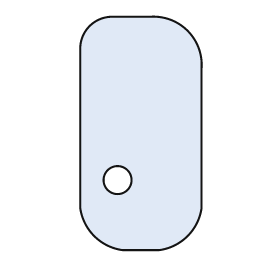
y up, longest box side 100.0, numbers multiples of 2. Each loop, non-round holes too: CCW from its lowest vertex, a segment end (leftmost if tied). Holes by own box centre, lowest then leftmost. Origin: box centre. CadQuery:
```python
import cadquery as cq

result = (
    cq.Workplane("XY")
    .moveTo(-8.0, -50.0)
    .lineTo(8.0, -50.0)
    .threePointArc((20.0, -44.0), (26.0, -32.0))
    .lineTo(26.0, 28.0)
    .threePointArc((20.0, 44.0), (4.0, 50.0))
    .lineTo(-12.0, 50.0)
    .threePointArc((-22.0, 46.0), (-26.0, 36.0))
    .lineTo(-26.0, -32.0)
    .threePointArc((-20.0, -44.0), (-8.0, -50.0))
    .close()
    .moveTo(-10.0, -20.0)
    .circle(6.0)
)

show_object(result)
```